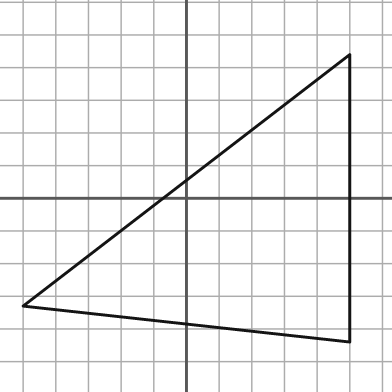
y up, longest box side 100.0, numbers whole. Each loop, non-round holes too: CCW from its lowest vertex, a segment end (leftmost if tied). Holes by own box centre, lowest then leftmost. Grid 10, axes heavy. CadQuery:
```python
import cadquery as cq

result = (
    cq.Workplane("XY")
    .moveTo(50.0, -44.0)
    .lineTo(50.0, 44.0)
    .lineTo(-50.0, -33.0)
    .close()
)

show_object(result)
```